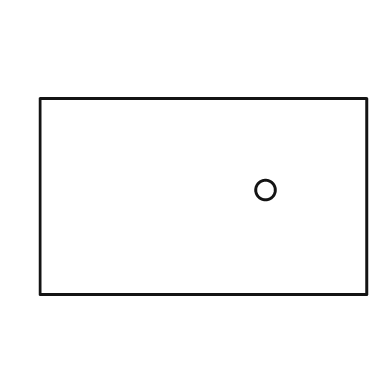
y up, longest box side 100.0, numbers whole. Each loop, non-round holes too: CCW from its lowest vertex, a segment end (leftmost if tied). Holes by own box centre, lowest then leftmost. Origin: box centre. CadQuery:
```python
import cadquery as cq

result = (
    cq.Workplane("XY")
    .moveTo(-50.0, -30.0)
    .lineTo(50.0, -30.0)
    .lineTo(50.0, 30.0)
    .lineTo(-50.0, 30.0)
    .close()
    .moveTo(19.0, 2.0)
    .circle(3.0)
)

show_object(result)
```